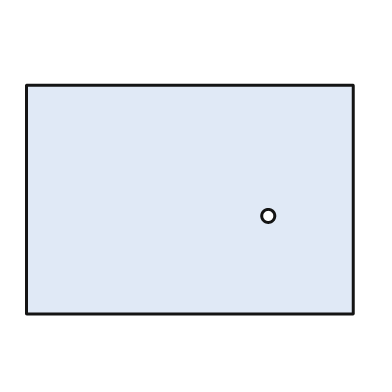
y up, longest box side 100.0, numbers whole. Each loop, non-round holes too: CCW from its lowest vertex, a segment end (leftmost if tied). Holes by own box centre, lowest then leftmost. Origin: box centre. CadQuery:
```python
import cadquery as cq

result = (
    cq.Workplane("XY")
    .moveTo(-50.0, -35.0)
    .lineTo(50.0, -35.0)
    .lineTo(50.0, 35.0)
    .lineTo(-50.0, 35.0)
    .close()
    .moveTo(24.0, -5.0)
    .circle(2.0)
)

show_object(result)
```